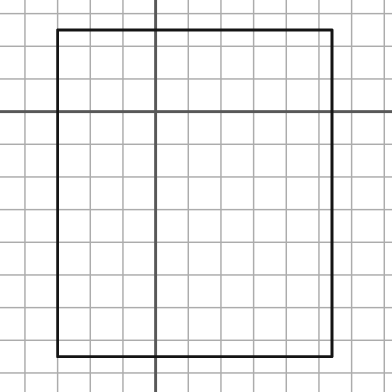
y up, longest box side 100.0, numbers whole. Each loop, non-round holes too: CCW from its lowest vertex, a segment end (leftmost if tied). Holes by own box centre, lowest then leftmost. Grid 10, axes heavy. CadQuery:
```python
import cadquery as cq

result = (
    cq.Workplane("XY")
    .moveTo(-30.0, -75.0)
    .lineTo(54.0, -75.0)
    .lineTo(54.0, 25.0)
    .lineTo(-30.0, 25.0)
    .close()
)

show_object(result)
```